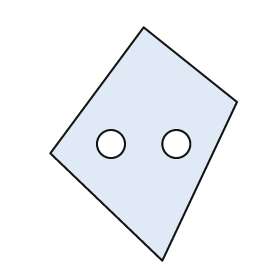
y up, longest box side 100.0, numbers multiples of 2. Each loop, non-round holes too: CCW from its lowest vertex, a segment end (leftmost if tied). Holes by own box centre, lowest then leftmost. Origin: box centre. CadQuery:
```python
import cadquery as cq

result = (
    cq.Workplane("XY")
    .moveTo(8.0, -50.0)
    .lineTo(40.0, 18.0)
    .lineTo(0.0, 50.0)
    .lineTo(-40.0, -4.0)
    .close()
    .moveTo(-14.0, 0.0)
    .circle(6.0)
    .moveTo(14.0, 0.0)
    .circle(6.0)
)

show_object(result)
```